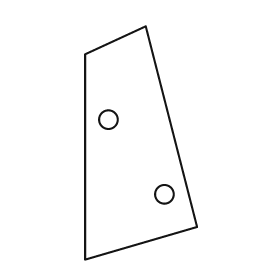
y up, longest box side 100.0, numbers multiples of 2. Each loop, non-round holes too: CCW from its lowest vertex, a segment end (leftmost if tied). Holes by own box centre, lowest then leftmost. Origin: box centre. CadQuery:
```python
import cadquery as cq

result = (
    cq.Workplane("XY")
    .moveTo(-24.0, -50.0)
    .lineTo(24.0, -36.0)
    .lineTo(2.0, 50.0)
    .lineTo(-24.0, 38.0)
    .close()
    .moveTo(10.0, -22.0)
    .circle(4.0)
    .moveTo(-14.0, 10.0)
    .circle(4.0)
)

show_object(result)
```